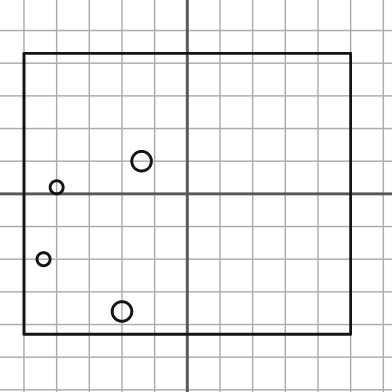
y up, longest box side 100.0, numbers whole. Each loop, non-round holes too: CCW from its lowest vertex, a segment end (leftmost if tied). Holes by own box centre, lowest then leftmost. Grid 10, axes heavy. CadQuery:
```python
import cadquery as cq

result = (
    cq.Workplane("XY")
    .moveTo(-50.0, -43.0)
    .lineTo(50.0, -43.0)
    .lineTo(50.0, 43.0)
    .lineTo(-50.0, 43.0)
    .close()
    .moveTo(-20.0, -36.0)
    .circle(3.0)
    .moveTo(-44.0, -20.0)
    .circle(2.0)
    .moveTo(-40.0, 2.0)
    .circle(2.0)
    .moveTo(-14.0, 10.0)
    .circle(3.0)
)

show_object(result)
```